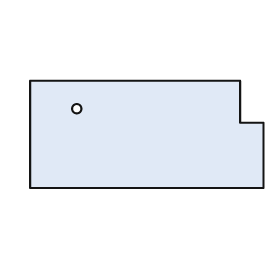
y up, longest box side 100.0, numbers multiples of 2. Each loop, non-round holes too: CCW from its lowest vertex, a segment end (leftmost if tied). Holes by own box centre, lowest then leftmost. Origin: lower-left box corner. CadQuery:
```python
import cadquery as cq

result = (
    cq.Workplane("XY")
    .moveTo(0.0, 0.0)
    .lineTo(100.0, 0.0)
    .lineTo(100.0, 28.0)
    .lineTo(90.0, 28.0)
    .lineTo(90.0, 46.0)
    .lineTo(0.0, 46.0)
    .close()
    .moveTo(20.0, 34.0)
    .circle(2.0)
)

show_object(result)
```